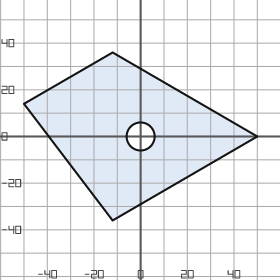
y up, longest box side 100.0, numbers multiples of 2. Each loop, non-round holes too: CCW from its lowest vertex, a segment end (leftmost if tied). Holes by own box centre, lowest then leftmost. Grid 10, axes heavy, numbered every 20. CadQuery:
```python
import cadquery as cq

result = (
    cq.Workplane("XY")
    .moveTo(-12.0, -36.0)
    .lineTo(50.0, 0.0)
    .lineTo(-12.0, 36.0)
    .lineTo(-50.0, 14.0)
    .close()
    .moveTo(0.0, 0.0)
    .circle(6.0)
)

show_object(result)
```